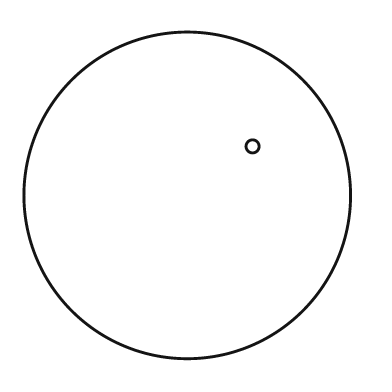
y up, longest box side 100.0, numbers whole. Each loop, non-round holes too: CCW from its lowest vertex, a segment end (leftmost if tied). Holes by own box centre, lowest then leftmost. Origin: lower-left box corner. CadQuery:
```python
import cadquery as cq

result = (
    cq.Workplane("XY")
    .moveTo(50.0, 50.0)
    .circle(50.0)
    .moveTo(70.0, 65.0)
    .circle(2.0)
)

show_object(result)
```